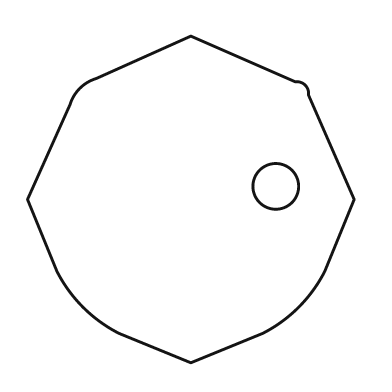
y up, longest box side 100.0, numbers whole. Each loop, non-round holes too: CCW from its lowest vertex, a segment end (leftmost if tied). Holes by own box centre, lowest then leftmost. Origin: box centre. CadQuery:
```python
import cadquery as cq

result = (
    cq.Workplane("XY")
    .moveTo(0.0, -50.0)
    .lineTo(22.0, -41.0)
    .threePointArc((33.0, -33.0), (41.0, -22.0))
    .lineTo(50.0, 0.0)
    .lineTo(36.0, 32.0)
    .threePointArc((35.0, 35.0), (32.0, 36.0))
    .lineTo(0.0, 50.0)
    .lineTo(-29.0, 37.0)
    .threePointArc((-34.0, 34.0), (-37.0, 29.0))
    .lineTo(-50.0, 0.0)
    .lineTo(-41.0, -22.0)
    .threePointArc((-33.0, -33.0), (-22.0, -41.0))
    .close()
    .moveTo(26.0, 4.0)
    .circle(7.0)
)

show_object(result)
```